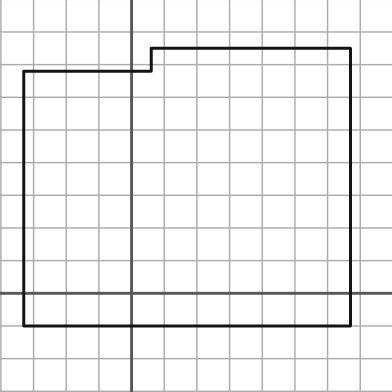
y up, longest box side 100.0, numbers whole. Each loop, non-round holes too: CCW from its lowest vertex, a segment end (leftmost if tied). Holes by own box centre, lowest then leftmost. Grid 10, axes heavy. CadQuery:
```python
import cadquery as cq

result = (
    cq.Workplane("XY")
    .moveTo(-33.0, -10.0)
    .lineTo(67.0, -10.0)
    .lineTo(67.0, 75.0)
    .lineTo(6.0, 75.0)
    .lineTo(6.0, 68.0)
    .lineTo(-33.0, 68.0)
    .close()
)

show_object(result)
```